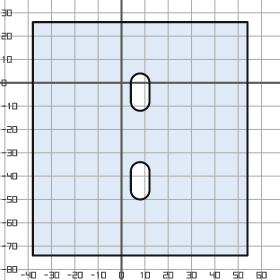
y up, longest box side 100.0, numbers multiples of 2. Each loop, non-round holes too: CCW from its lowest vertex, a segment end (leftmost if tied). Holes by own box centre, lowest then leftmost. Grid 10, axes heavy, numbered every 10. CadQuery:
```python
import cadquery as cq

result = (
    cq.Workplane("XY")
    .moveTo(-38.0, -74.0)
    .lineTo(54.0, -74.0)
    .lineTo(54.0, 26.0)
    .lineTo(-38.0, 26.0)
    .close()
    .moveTo(4.0, -46.0)
    .threePointArc((8.0, -50.0), (12.0, -46.0))
    .lineTo(12.0, -38.0)
    .threePointArc((8.0, -34.0), (4.0, -38.0))
    .close()
    .moveTo(4.0, -8.0)
    .threePointArc((8.0, -12.0), (12.0, -8.0))
    .lineTo(12.0, 0.0)
    .threePointArc((8.0, 4.0), (4.0, 0.0))
    .close()
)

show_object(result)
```